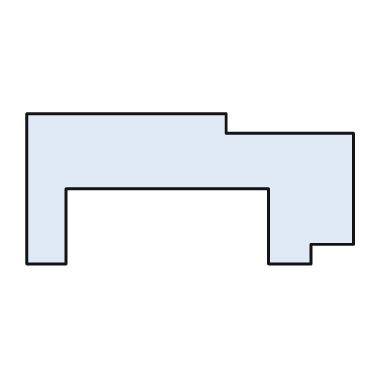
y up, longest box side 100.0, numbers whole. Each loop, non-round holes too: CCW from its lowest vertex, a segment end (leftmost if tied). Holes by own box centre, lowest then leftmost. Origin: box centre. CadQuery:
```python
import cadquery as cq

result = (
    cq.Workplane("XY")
    .moveTo(-50.0, -23.0)
    .lineTo(-38.0, -23.0)
    .lineTo(-38.0, 0.0)
    .lineTo(24.0, 0.0)
    .lineTo(24.0, -23.0)
    .lineTo(37.0, -23.0)
    .lineTo(37.0, -17.0)
    .lineTo(50.0, -17.0)
    .lineTo(50.0, 17.0)
    .lineTo(11.0, 17.0)
    .lineTo(11.0, 23.0)
    .lineTo(-50.0, 23.0)
    .close()
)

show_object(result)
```